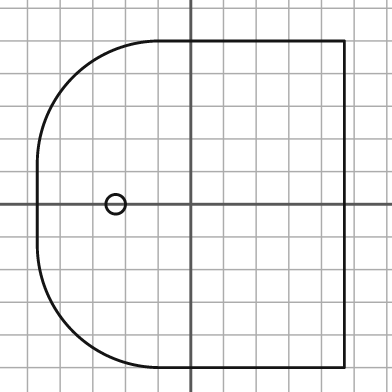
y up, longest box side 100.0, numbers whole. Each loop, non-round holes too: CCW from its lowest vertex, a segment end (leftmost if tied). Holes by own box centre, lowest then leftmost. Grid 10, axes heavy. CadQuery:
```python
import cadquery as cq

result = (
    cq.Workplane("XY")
    .moveTo(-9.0, -50.0)
    .lineTo(47.0, -50.0)
    .lineTo(47.0, 50.0)
    .lineTo(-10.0, 50.0)
    .threePointArc((-36.0, 39.0), (-47.0, 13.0))
    .lineTo(-47.0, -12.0)
    .threePointArc((-36.0, -39.0), (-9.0, -50.0))
    .close()
    .moveTo(-23.0, 0.0)
    .circle(3.0)
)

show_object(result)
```